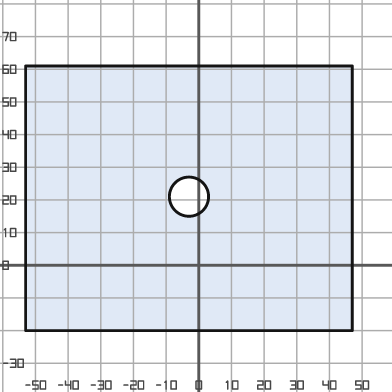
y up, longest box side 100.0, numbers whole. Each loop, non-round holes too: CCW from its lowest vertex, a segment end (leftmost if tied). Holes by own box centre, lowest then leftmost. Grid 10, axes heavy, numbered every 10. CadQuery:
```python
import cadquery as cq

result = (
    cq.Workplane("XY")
    .moveTo(-53.0, -20.0)
    .lineTo(47.0, -20.0)
    .lineTo(47.0, 61.0)
    .lineTo(-53.0, 61.0)
    .close()
    .moveTo(-3.0, 21.0)
    .circle(6.0)
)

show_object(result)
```